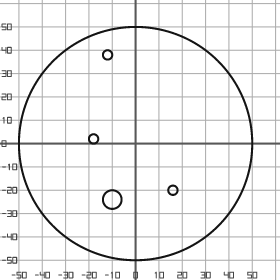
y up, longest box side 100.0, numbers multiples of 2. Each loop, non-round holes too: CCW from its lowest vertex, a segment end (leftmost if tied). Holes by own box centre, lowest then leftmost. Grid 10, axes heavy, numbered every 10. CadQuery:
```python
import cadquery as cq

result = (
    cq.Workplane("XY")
    .moveTo(0.0, 0.0)
    .circle(50.0)
    .moveTo(-10.0, -24.0)
    .circle(4.0)
    .moveTo(16.0, -20.0)
    .circle(2.0)
    .moveTo(-18.0, 2.0)
    .circle(2.0)
    .moveTo(-12.0, 38.0)
    .circle(2.0)
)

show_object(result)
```